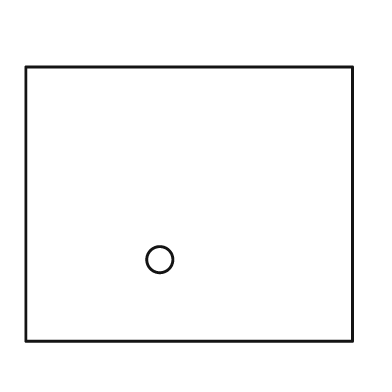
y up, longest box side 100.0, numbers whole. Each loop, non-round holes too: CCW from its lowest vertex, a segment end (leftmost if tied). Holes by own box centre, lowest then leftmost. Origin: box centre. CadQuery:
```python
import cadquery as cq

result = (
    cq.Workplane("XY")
    .moveTo(-50.0, -42.0)
    .lineTo(50.0, -42.0)
    .lineTo(50.0, 42.0)
    .lineTo(-50.0, 42.0)
    .close()
    .moveTo(-9.0, -17.0)
    .circle(4.0)
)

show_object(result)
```